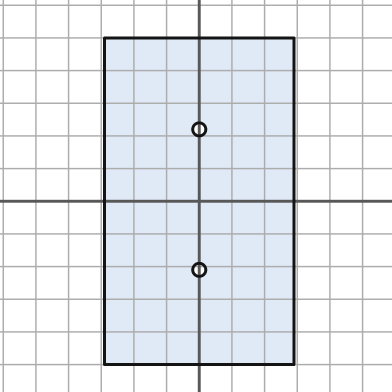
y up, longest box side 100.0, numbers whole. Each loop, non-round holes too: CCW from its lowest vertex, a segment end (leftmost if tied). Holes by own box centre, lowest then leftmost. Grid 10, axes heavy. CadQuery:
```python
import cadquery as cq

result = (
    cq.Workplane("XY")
    .moveTo(-29.0, -50.0)
    .lineTo(29.0, -50.0)
    .lineTo(29.0, 50.0)
    .lineTo(-29.0, 50.0)
    .close()
    .moveTo(0.0, -21.0)
    .circle(2.0)
    .moveTo(0.0, 22.0)
    .circle(2.0)
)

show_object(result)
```